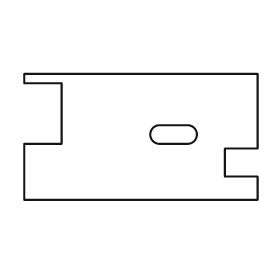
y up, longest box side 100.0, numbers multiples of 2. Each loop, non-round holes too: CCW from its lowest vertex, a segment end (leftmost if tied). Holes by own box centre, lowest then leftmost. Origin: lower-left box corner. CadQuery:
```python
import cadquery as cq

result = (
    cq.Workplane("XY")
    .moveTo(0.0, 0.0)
    .lineTo(100.0, 0.0)
    .lineTo(100.0, 10.0)
    .lineTo(86.0, 10.0)
    .lineTo(86.0, 22.0)
    .lineTo(100.0, 22.0)
    .lineTo(100.0, 54.0)
    .lineTo(0.0, 54.0)
    .lineTo(0.0, 50.0)
    .lineTo(16.0, 50.0)
    .lineTo(16.0, 24.0)
    .lineTo(0.0, 24.0)
    .close()
    .moveTo(58.0, 24.0)
    .lineTo(70.0, 24.0)
    .threePointArc((74.0, 28.0), (70.0, 32.0))
    .lineTo(58.0, 32.0)
    .threePointArc((54.0, 28.0), (58.0, 24.0))
    .close()
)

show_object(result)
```